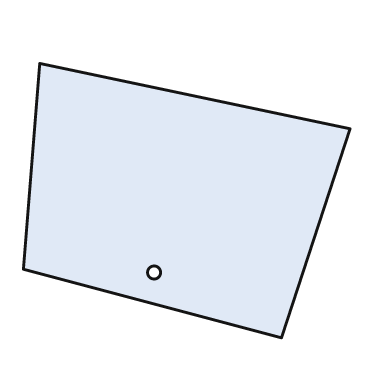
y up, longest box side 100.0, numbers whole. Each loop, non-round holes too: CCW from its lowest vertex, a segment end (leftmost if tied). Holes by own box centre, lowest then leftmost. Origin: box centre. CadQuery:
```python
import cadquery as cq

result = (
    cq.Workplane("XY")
    .moveTo(29.0, -42.0)
    .lineTo(50.0, 22.0)
    .lineTo(-45.0, 42.0)
    .lineTo(-50.0, -21.0)
    .close()
    .moveTo(-10.0, -22.0)
    .circle(2.0)
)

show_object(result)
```